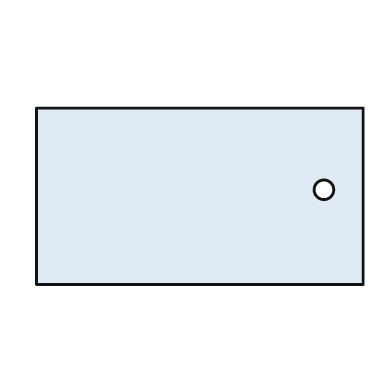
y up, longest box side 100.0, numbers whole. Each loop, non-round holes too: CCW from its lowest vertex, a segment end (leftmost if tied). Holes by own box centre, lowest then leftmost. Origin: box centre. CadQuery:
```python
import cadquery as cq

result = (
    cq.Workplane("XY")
    .moveTo(-50.0, -27.0)
    .lineTo(50.0, -27.0)
    .lineTo(50.0, 27.0)
    .lineTo(-50.0, 27.0)
    .close()
    .moveTo(38.0, 2.0)
    .circle(3.0)
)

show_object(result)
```